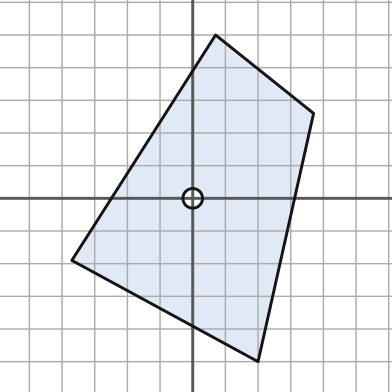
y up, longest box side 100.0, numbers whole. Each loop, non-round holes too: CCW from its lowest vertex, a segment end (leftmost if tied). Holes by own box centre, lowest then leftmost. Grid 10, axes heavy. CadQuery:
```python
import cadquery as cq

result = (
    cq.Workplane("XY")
    .moveTo(20.0, -50.0)
    .lineTo(37.0, 26.0)
    .lineTo(7.0, 50.0)
    .lineTo(-37.0, -19.0)
    .close()
    .moveTo(0.0, 0.0)
    .circle(3.0)
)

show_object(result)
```